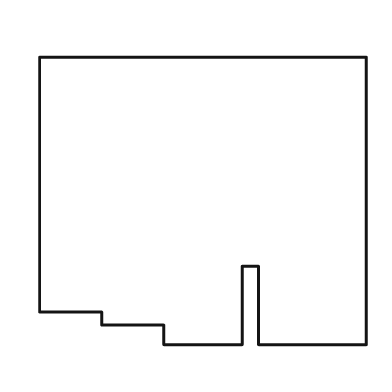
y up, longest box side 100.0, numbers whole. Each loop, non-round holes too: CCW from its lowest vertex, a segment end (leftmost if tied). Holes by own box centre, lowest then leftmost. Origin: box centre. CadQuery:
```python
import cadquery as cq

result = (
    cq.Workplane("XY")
    .moveTo(-12.0, -44.0)
    .lineTo(12.0, -44.0)
    .lineTo(12.0, -20.0)
    .lineTo(17.0, -20.0)
    .lineTo(17.0, -44.0)
    .lineTo(50.0, -44.0)
    .lineTo(50.0, 44.0)
    .lineTo(-50.0, 44.0)
    .lineTo(-50.0, -34.0)
    .lineTo(-31.0, -34.0)
    .lineTo(-31.0, -38.0)
    .lineTo(-12.0, -38.0)
    .close()
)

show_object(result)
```